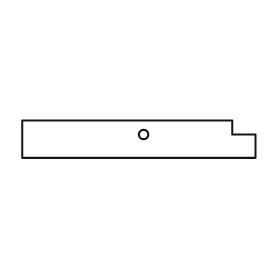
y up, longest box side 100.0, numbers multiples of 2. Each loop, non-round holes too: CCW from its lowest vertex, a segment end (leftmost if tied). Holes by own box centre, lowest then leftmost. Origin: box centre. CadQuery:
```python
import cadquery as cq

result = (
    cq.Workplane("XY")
    .moveTo(-50.0, -8.0)
    .lineTo(50.0, -8.0)
    .lineTo(50.0, 2.0)
    .lineTo(40.0, 2.0)
    .lineTo(40.0, 8.0)
    .lineTo(-50.0, 8.0)
    .close()
    .moveTo(2.0, 2.0)
    .circle(2.0)
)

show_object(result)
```